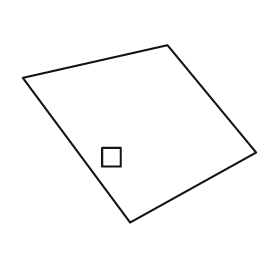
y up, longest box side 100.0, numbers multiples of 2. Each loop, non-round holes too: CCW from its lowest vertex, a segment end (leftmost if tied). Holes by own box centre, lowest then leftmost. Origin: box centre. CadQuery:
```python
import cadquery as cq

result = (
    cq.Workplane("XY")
    .moveTo(-4.0, -38.0)
    .lineTo(50.0, -8.0)
    .lineTo(12.0, 38.0)
    .lineTo(-50.0, 24.0)
    .close()
    .moveTo(-16.0, -14.0)
    .lineTo(-8.0, -14.0)
    .lineTo(-8.0, -6.0)
    .lineTo(-16.0, -6.0)
    .close()
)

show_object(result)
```